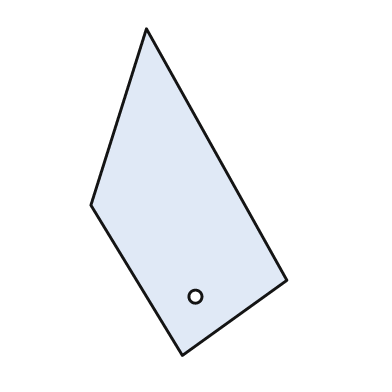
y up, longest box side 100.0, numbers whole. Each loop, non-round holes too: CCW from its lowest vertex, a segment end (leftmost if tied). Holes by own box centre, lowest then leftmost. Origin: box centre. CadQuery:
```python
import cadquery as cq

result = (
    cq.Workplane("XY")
    .moveTo(-2.0, -50.0)
    .lineTo(30.0, -27.0)
    .lineTo(-13.0, 50.0)
    .lineTo(-30.0, -4.0)
    .close()
    .moveTo(2.0, -32.0)
    .circle(2.0)
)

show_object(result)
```